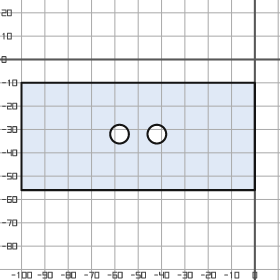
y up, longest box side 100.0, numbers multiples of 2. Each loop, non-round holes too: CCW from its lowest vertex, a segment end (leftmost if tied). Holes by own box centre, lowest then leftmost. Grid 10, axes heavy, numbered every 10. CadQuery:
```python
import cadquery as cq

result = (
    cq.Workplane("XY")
    .moveTo(-100.0, -56.0)
    .lineTo(0.0, -56.0)
    .lineTo(0.0, -10.0)
    .lineTo(-100.0, -10.0)
    .close()
    .moveTo(-58.0, -32.0)
    .circle(4.0)
    .moveTo(-42.0, -32.0)
    .circle(4.0)
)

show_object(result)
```